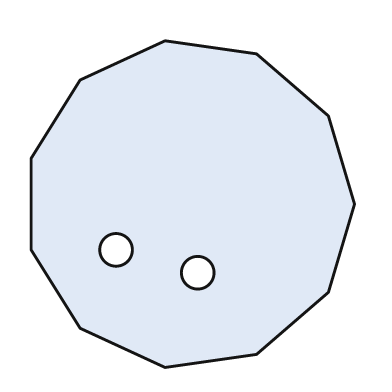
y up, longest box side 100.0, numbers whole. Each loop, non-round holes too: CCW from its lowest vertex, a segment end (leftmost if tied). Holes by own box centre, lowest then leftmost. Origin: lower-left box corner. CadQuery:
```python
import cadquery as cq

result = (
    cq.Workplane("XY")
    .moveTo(41.0, 0.0)
    .lineTo(69.0, 4.0)
    .lineTo(91.0, 23.0)
    .lineTo(99.0, 50.0)
    .lineTo(91.0, 77.0)
    .lineTo(69.0, 96.0)
    .lineTo(41.0, 100.0)
    .lineTo(15.0, 88.0)
    .lineTo(0.0, 64.0)
    .lineTo(0.0, 36.0)
    .lineTo(15.0, 12.0)
    .close()
    .moveTo(51.0, 29.0)
    .circle(5.0)
    .moveTo(26.0, 36.0)
    .circle(5.0)
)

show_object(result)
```